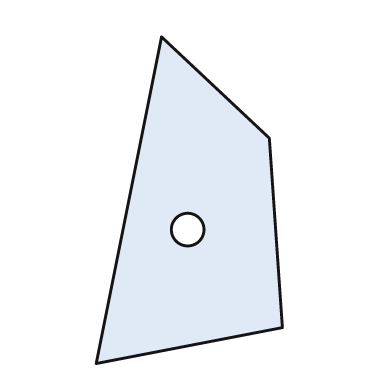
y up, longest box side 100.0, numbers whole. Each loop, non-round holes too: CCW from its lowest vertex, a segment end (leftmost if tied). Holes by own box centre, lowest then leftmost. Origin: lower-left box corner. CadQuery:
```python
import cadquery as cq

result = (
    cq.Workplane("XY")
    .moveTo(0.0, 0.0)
    .lineTo(57.0, 11.0)
    .lineTo(53.0, 69.0)
    .lineTo(20.0, 100.0)
    .close()
    .moveTo(28.0, 41.0)
    .circle(5.0)
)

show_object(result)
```